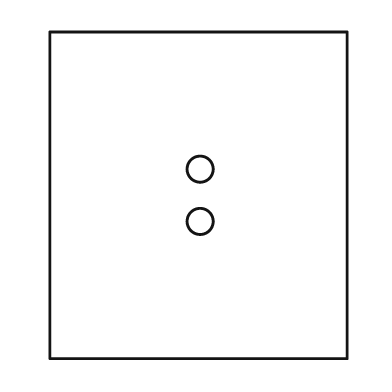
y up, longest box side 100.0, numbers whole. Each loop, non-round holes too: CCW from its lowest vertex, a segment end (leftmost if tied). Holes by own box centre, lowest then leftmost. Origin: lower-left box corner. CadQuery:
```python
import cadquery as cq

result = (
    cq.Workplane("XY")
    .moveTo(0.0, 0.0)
    .lineTo(91.0, 0.0)
    .lineTo(91.0, 100.0)
    .lineTo(0.0, 100.0)
    .close()
    .moveTo(46.0, 42.0)
    .circle(4.0)
    .moveTo(46.0, 58.0)
    .circle(4.0)
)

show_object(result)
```